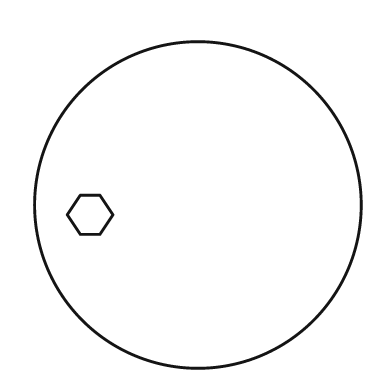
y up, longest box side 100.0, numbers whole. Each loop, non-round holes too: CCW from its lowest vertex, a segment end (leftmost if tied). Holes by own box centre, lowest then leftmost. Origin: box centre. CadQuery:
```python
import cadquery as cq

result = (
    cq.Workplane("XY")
    .moveTo(0.0, 0.0)
    .circle(50.0)
    .moveTo(-36.0, -9.0)
    .lineTo(-30.0, -9.0)
    .lineTo(-26.0, -3.0)
    .lineTo(-30.0, 3.0)
    .lineTo(-36.0, 3.0)
    .lineTo(-40.0, -3.0)
    .close()
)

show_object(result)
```